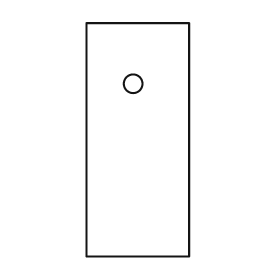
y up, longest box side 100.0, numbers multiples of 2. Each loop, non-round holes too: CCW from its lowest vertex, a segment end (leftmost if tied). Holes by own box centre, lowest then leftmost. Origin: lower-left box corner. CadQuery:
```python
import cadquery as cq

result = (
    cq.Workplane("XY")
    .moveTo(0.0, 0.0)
    .lineTo(44.0, 0.0)
    .lineTo(44.0, 100.0)
    .lineTo(0.0, 100.0)
    .close()
    .moveTo(20.0, 74.0)
    .circle(4.0)
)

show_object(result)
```